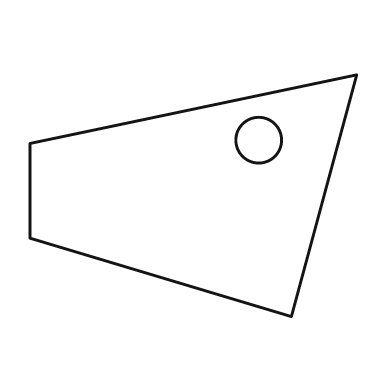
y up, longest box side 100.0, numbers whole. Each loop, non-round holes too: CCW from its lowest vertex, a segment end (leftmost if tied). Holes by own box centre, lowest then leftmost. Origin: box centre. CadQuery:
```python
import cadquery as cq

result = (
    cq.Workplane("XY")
    .moveTo(30.0, -37.0)
    .lineTo(50.0, 37.0)
    .lineTo(-50.0, 16.0)
    .lineTo(-50.0, -13.0)
    .close()
    .moveTo(20.0, 17.0)
    .circle(7.0)
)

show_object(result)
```